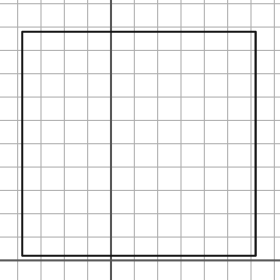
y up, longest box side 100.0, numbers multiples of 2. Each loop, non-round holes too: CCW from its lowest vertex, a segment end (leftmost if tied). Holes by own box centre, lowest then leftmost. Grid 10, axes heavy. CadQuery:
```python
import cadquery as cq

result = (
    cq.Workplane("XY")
    .moveTo(-38.0, 2.0)
    .lineTo(62.0, 2.0)
    .lineTo(62.0, 98.0)
    .lineTo(-38.0, 98.0)
    .close()
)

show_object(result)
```